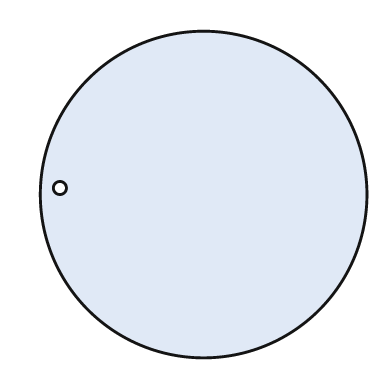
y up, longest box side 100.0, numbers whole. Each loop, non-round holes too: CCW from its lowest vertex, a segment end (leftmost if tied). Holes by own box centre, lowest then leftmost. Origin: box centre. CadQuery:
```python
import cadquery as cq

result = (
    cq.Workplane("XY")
    .moveTo(0.0, 0.0)
    .circle(50.0)
    .moveTo(-44.0, 2.0)
    .circle(2.0)
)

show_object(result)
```